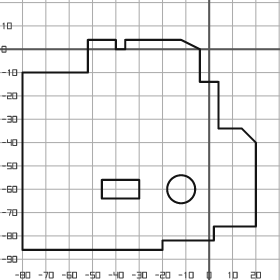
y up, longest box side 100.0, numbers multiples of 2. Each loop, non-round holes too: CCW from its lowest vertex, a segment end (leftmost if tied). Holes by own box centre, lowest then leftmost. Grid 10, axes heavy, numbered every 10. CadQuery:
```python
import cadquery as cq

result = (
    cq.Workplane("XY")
    .moveTo(-80.0, -86.0)
    .lineTo(-20.0, -86.0)
    .lineTo(-20.0, -82.0)
    .lineTo(2.0, -82.0)
    .lineTo(2.0, -76.0)
    .lineTo(20.0, -76.0)
    .lineTo(20.0, -40.0)
    .lineTo(14.0, -34.0)
    .lineTo(4.0, -34.0)
    .lineTo(4.0, -14.0)
    .lineTo(-4.0, -14.0)
    .lineTo(-4.0, 0.0)
    .lineTo(-12.0, 4.0)
    .lineTo(-36.0, 4.0)
    .lineTo(-36.0, 0.0)
    .lineTo(-40.0, 0.0)
    .lineTo(-40.0, 4.0)
    .lineTo(-52.0, 4.0)
    .lineTo(-52.0, -10.0)
    .lineTo(-80.0, -10.0)
    .close()
    .moveTo(-46.0, -64.0)
    .lineTo(-30.0, -64.0)
    .lineTo(-30.0, -56.0)
    .lineTo(-46.0, -56.0)
    .close()
    .moveTo(-12.0, -60.0)
    .circle(6.0)
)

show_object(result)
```